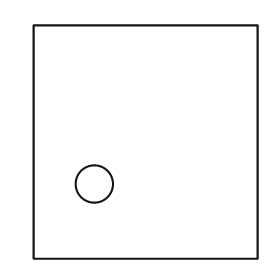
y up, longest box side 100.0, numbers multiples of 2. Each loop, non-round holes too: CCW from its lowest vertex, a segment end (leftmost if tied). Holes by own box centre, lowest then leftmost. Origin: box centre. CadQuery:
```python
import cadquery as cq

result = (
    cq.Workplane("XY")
    .moveTo(-48.0, -50.0)
    .lineTo(48.0, -50.0)
    .lineTo(48.0, 50.0)
    .lineTo(-48.0, 50.0)
    .close()
    .moveTo(-22.0, -18.0)
    .circle(8.0)
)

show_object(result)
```